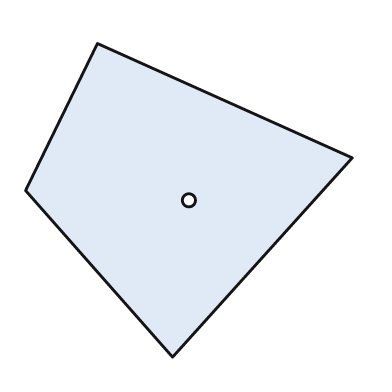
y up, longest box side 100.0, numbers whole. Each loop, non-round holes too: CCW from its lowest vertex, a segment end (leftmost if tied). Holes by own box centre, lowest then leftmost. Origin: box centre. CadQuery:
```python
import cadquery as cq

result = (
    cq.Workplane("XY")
    .moveTo(-5.0, -48.0)
    .lineTo(50.0, 13.0)
    .lineTo(-28.0, 48.0)
    .lineTo(-50.0, 3.0)
    .close()
    .moveTo(0.0, 0.0)
    .circle(2.0)
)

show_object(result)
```